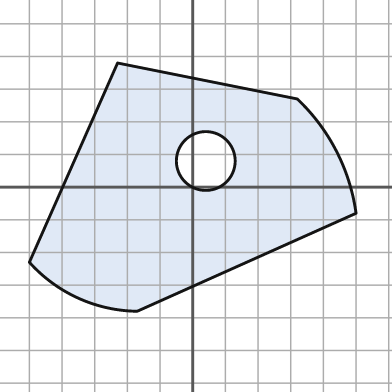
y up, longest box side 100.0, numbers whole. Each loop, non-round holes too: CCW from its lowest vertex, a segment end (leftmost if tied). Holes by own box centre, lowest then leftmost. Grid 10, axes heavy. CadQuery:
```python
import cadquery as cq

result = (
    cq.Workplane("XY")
    .moveTo(-17.0, -38.0)
    .lineTo(50.0, -8.0)
    .threePointArc((44.0, 11.0), (32.0, 27.0))
    .lineTo(-23.0, 38.0)
    .lineTo(-50.0, -23.0)
    .threePointArc((-35.0, -34.0), (-17.0, -38.0))
    .close()
    .moveTo(4.0, 8.0)
    .circle(9.0)
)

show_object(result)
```